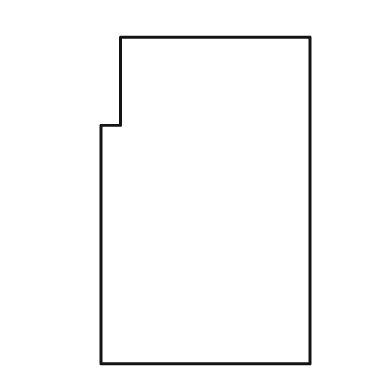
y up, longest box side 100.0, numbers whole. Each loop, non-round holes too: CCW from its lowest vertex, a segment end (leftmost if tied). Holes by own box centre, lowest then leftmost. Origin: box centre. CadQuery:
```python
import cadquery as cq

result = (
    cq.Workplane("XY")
    .moveTo(-32.0, -50.0)
    .lineTo(32.0, -50.0)
    .lineTo(32.0, 50.0)
    .lineTo(-26.0, 50.0)
    .lineTo(-26.0, 23.0)
    .lineTo(-32.0, 23.0)
    .close()
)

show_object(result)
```